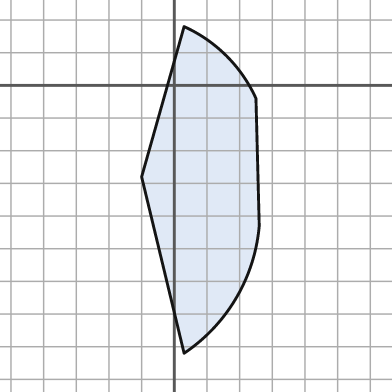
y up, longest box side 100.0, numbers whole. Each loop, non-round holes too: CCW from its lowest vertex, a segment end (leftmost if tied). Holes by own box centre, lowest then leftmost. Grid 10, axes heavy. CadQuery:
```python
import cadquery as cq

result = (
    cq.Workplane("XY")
    .moveTo(3.0, -82.0)
    .threePointArc((19.0, -65.0), (26.0, -43.0))
    .lineTo(25.0, -4.0)
    .threePointArc((16.0, 9.0), (3.0, 18.0))
    .lineTo(-10.0, -28.0)
    .close()
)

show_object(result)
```